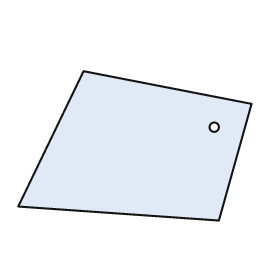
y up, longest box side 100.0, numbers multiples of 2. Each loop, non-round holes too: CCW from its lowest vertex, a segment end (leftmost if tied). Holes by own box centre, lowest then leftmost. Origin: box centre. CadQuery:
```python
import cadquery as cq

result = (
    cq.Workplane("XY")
    .moveTo(36.0, -32.0)
    .lineTo(50.0, 18.0)
    .lineTo(-22.0, 32.0)
    .lineTo(-50.0, -26.0)
    .close()
    .moveTo(34.0, 8.0)
    .circle(2.0)
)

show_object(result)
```